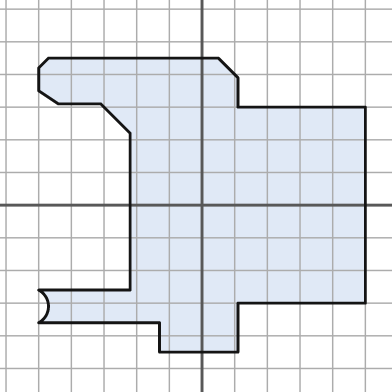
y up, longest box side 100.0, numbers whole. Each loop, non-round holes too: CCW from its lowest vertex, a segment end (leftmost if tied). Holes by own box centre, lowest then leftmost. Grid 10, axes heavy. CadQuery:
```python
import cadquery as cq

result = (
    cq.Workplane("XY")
    .moveTo(-13.0, -45.0)
    .lineTo(11.0, -45.0)
    .lineTo(11.0, -30.0)
    .lineTo(50.0, -30.0)
    .lineTo(50.0, 30.0)
    .lineTo(11.0, 30.0)
    .lineTo(11.0, 39.0)
    .lineTo(5.0, 45.0)
    .lineTo(-47.0, 45.0)
    .lineTo(-50.0, 42.0)
    .lineTo(-50.0, 35.0)
    .lineTo(-44.0, 31.0)
    .lineTo(-31.0, 31.0)
    .lineTo(-22.0, 22.0)
    .lineTo(-22.0, -26.0)
    .lineTo(-50.0, -26.0)
    .threePointArc((-47.0, -31.0), (-50.0, -36.0))
    .lineTo(-13.0, -36.0)
    .close()
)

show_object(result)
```